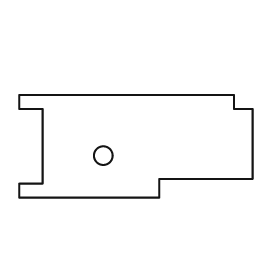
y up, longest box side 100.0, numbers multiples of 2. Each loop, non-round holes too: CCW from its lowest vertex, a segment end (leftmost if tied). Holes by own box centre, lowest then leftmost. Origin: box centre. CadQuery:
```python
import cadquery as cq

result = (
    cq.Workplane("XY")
    .moveTo(-50.0, -22.0)
    .lineTo(10.0, -22.0)
    .lineTo(10.0, -14.0)
    .lineTo(50.0, -14.0)
    .lineTo(50.0, 16.0)
    .lineTo(42.0, 16.0)
    .lineTo(42.0, 22.0)
    .lineTo(-50.0, 22.0)
    .lineTo(-50.0, 16.0)
    .lineTo(-40.0, 16.0)
    .lineTo(-40.0, -16.0)
    .lineTo(-50.0, -16.0)
    .close()
    .moveTo(-14.0, -4.0)
    .circle(4.0)
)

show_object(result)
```